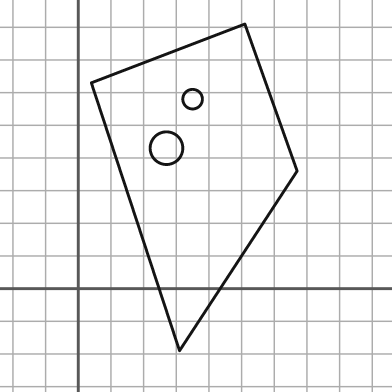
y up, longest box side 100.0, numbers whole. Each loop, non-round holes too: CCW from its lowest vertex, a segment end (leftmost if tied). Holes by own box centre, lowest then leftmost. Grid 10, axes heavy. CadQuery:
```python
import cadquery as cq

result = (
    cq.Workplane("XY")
    .moveTo(31.0, -19.0)
    .lineTo(67.0, 36.0)
    .lineTo(51.0, 81.0)
    .lineTo(4.0, 63.0)
    .close()
    .moveTo(27.0, 43.0)
    .circle(5.0)
    .moveTo(35.0, 58.0)
    .circle(3.0)
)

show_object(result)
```